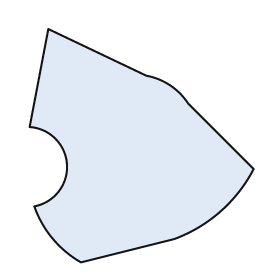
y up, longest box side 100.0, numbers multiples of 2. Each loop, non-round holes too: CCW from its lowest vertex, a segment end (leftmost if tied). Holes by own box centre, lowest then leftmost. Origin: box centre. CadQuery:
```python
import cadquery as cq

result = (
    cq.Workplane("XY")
    .moveTo(-26.0, -50.0)
    .lineTo(14.0, -40.0)
    .threePointArc((34.0, -28.0), (48.0, -10.0))
    .lineTo(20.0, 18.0)
    .threePointArc((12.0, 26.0), (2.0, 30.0))
    .lineTo(-40.0, 50.0)
    .lineTo(-48.0, 8.0)
    .threePointArc((-32.0, -8.0), (-46.0, -26.0))
    .threePointArc((-38.0, -40.0), (-26.0, -50.0))
    .close()
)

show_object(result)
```